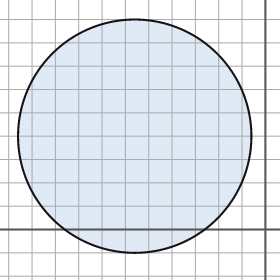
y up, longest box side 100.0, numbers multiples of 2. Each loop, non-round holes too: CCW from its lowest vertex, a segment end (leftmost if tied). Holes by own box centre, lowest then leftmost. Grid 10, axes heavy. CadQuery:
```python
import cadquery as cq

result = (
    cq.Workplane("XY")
    .moveTo(-56.0, 40.0)
    .circle(50.0)
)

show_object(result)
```